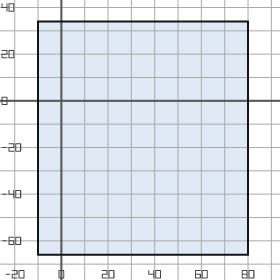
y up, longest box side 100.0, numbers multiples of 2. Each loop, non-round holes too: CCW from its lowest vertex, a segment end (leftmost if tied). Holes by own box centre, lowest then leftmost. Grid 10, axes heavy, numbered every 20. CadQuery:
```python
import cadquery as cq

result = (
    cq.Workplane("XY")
    .moveTo(-10.0, -66.0)
    .lineTo(80.0, -66.0)
    .lineTo(80.0, 34.0)
    .lineTo(-10.0, 34.0)
    .close()
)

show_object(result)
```